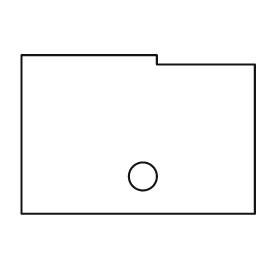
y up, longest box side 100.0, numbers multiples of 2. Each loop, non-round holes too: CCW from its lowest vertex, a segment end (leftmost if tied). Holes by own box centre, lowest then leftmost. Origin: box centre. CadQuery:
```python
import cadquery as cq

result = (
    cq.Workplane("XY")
    .moveTo(-50.0, -34.0)
    .lineTo(50.0, -34.0)
    .lineTo(50.0, 30.0)
    .lineTo(8.0, 30.0)
    .lineTo(8.0, 34.0)
    .lineTo(-50.0, 34.0)
    .close()
    .moveTo(2.0, -18.0)
    .circle(6.0)
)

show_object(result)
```